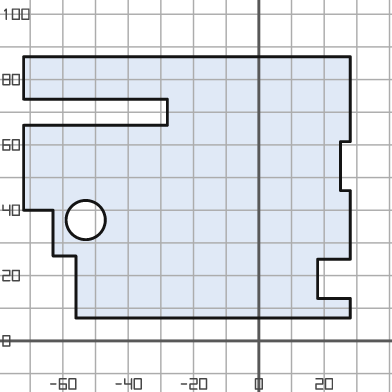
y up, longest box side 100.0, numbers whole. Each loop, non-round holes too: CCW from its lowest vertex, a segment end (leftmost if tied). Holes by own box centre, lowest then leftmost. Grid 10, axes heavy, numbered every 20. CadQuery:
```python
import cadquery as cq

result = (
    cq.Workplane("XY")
    .moveTo(-56.0, 7.0)
    .lineTo(28.0, 7.0)
    .lineTo(28.0, 13.0)
    .lineTo(18.0, 13.0)
    .lineTo(18.0, 25.0)
    .lineTo(28.0, 25.0)
    .lineTo(28.0, 46.0)
    .lineTo(25.0, 46.0)
    .lineTo(25.0, 61.0)
    .lineTo(28.0, 61.0)
    .lineTo(28.0, 87.0)
    .lineTo(-72.0, 87.0)
    .lineTo(-72.0, 74.0)
    .lineTo(-28.0, 74.0)
    .lineTo(-28.0, 66.0)
    .lineTo(-72.0, 66.0)
    .lineTo(-72.0, 40.0)
    .lineTo(-63.0, 40.0)
    .lineTo(-63.0, 26.0)
    .lineTo(-56.0, 26.0)
    .close()
    .moveTo(-53.0, 37.0)
    .circle(6.0)
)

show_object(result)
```